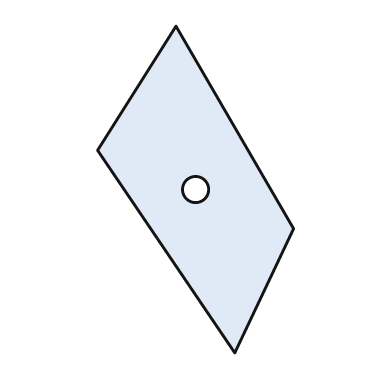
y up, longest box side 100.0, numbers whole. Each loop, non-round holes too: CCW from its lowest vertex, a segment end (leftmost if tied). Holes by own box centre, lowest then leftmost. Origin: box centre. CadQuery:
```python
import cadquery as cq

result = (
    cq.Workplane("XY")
    .moveTo(12.0, -50.0)
    .lineTo(30.0, -12.0)
    .lineTo(-6.0, 50.0)
    .lineTo(-30.0, 12.0)
    .close()
    .moveTo(0.0, 0.0)
    .circle(4.0)
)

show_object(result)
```